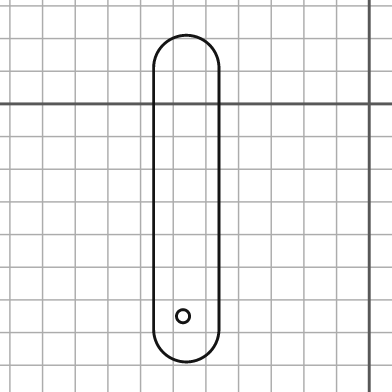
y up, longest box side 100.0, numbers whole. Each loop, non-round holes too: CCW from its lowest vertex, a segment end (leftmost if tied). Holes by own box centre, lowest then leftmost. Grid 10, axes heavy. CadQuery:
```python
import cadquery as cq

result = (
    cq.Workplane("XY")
    .moveTo(-66.0, -69.0)
    .threePointArc((-56.0, -79.0), (-46.0, -69.0))
    .lineTo(-46.0, 11.0)
    .threePointArc((-56.0, 21.0), (-66.0, 11.0))
    .close()
    .moveTo(-57.0, -65.0)
    .circle(2.0)
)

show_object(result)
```